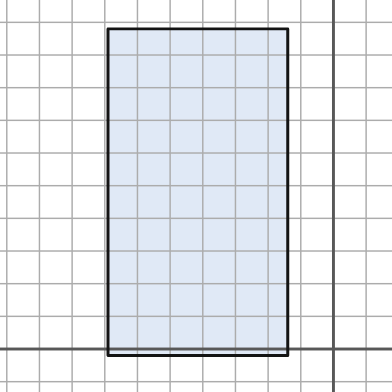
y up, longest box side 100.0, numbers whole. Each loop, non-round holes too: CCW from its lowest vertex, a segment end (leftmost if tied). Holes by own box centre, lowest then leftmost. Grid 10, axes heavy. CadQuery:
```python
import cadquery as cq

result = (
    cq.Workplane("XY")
    .moveTo(-69.0, -2.0)
    .lineTo(-14.0, -2.0)
    .lineTo(-14.0, 98.0)
    .lineTo(-69.0, 98.0)
    .close()
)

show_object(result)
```